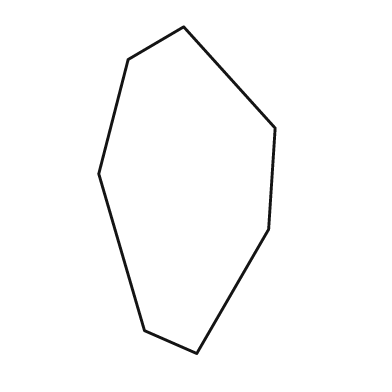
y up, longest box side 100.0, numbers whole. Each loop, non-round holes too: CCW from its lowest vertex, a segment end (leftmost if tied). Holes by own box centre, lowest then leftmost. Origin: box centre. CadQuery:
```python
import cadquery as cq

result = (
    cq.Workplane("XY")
    .moveTo(3.0, -50.0)
    .lineTo(25.0, -12.0)
    .lineTo(27.0, 19.0)
    .lineTo(-1.0, 50.0)
    .lineTo(-18.0, 40.0)
    .lineTo(-27.0, 5.0)
    .lineTo(-13.0, -43.0)
    .close()
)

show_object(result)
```